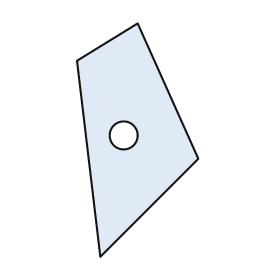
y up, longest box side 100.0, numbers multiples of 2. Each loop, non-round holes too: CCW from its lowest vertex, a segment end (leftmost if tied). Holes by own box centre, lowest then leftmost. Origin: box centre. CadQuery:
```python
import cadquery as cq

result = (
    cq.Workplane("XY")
    .moveTo(-16.0, -50.0)
    .lineTo(26.0, -8.0)
    .lineTo(0.0, 50.0)
    .lineTo(-26.0, 34.0)
    .close()
    .moveTo(-6.0, 2.0)
    .circle(6.0)
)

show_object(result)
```